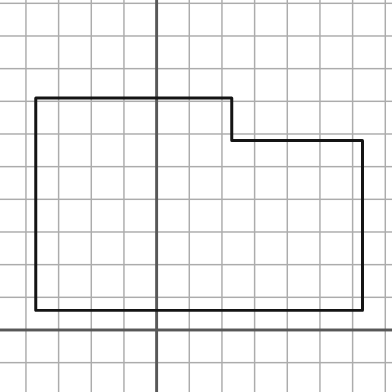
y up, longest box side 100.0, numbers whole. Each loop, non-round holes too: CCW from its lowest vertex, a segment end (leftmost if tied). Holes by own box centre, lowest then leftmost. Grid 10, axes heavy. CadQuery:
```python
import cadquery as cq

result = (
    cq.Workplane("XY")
    .moveTo(-37.0, 6.0)
    .lineTo(63.0, 6.0)
    .lineTo(63.0, 58.0)
    .lineTo(23.0, 58.0)
    .lineTo(23.0, 71.0)
    .lineTo(-37.0, 71.0)
    .close()
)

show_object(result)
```